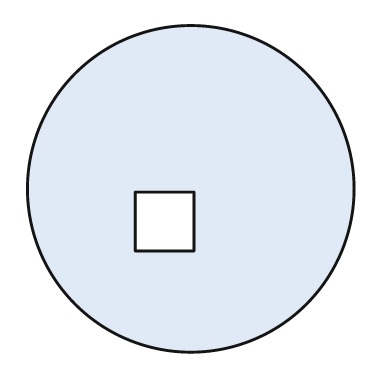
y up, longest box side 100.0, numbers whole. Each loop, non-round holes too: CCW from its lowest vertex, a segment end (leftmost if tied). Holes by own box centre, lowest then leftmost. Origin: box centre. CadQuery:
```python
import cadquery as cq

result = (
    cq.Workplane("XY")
    .moveTo(0.0, 0.0)
    .circle(50.0)
    .moveTo(-17.0, -19.0)
    .lineTo(1.0, -19.0)
    .lineTo(1.0, -1.0)
    .lineTo(-17.0, -1.0)
    .close()
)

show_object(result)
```